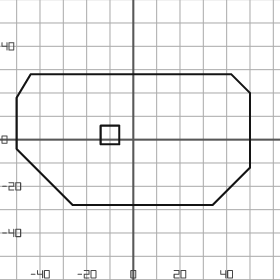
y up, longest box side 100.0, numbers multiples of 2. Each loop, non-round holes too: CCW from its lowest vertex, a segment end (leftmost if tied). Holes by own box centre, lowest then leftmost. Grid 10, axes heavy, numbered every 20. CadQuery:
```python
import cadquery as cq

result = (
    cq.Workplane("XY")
    .moveTo(-26.0, -28.0)
    .lineTo(34.0, -28.0)
    .lineTo(50.0, -12.0)
    .lineTo(50.0, 20.0)
    .lineTo(42.0, 28.0)
    .lineTo(-44.0, 28.0)
    .lineTo(-50.0, 18.0)
    .lineTo(-50.0, -4.0)
    .close()
    .moveTo(-14.0, -2.0)
    .lineTo(-6.0, -2.0)
    .lineTo(-6.0, 6.0)
    .lineTo(-14.0, 6.0)
    .close()
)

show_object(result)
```